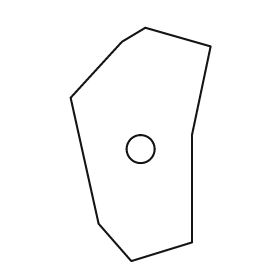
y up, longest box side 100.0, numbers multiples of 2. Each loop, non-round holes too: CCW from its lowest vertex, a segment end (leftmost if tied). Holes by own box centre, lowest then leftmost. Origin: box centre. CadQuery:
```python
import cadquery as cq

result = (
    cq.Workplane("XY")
    .moveTo(-4.0, -50.0)
    .lineTo(22.0, -42.0)
    .lineTo(22.0, 4.0)
    .lineTo(30.0, 42.0)
    .lineTo(2.0, 50.0)
    .lineTo(-8.0, 44.0)
    .lineTo(-30.0, 20.0)
    .lineTo(-18.0, -34.0)
    .close()
    .moveTo(0.0, -2.0)
    .circle(6.0)
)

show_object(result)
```